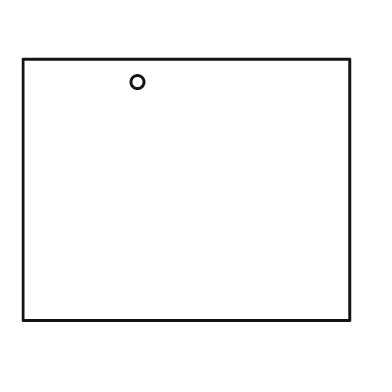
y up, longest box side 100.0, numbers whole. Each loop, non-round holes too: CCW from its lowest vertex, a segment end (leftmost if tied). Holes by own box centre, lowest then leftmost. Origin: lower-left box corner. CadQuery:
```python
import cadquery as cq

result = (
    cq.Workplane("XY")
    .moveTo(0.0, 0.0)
    .lineTo(100.0, 0.0)
    .lineTo(100.0, 80.0)
    .lineTo(0.0, 80.0)
    .close()
    .moveTo(35.0, 73.0)
    .circle(2.0)
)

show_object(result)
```